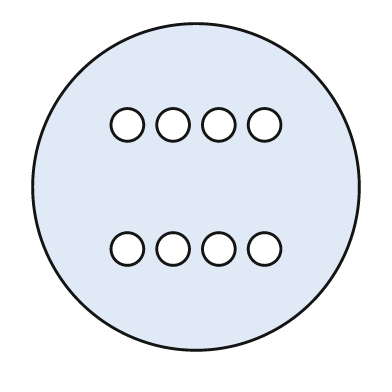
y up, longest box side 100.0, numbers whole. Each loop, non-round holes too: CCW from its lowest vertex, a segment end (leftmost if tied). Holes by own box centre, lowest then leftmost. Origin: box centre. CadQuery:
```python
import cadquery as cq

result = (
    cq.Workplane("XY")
    .moveTo(0.0, 0.0)
    .circle(50.0)
    .moveTo(-21.0, -19.0)
    .circle(5.0)
    .moveTo(-7.0, -19.0)
    .circle(5.0)
    .moveTo(7.0, -19.0)
    .circle(5.0)
    .moveTo(21.0, -19.0)
    .circle(5.0)
    .moveTo(-21.0, 19.0)
    .circle(5.0)
    .moveTo(-7.0, 19.0)
    .circle(5.0)
    .moveTo(7.0, 19.0)
    .circle(5.0)
    .moveTo(21.0, 19.0)
    .circle(5.0)
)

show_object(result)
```